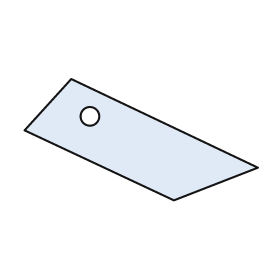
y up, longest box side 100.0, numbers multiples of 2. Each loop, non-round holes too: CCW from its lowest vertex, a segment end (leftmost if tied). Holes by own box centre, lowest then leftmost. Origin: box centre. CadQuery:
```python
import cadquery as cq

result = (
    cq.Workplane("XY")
    .moveTo(14.0, -26.0)
    .lineTo(50.0, -12.0)
    .lineTo(-30.0, 26.0)
    .lineTo(-50.0, 4.0)
    .close()
    .moveTo(-22.0, 10.0)
    .circle(4.0)
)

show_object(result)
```